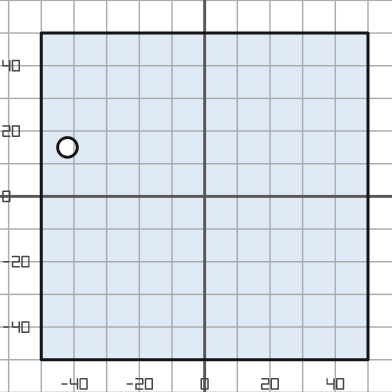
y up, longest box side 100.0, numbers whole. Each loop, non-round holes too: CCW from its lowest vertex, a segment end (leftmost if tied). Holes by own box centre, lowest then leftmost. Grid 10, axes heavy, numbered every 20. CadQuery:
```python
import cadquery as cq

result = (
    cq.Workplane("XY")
    .moveTo(-50.0, -50.0)
    .lineTo(50.0, -50.0)
    .lineTo(50.0, 50.0)
    .lineTo(-50.0, 50.0)
    .close()
    .moveTo(-42.0, 15.0)
    .circle(3.0)
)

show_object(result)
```